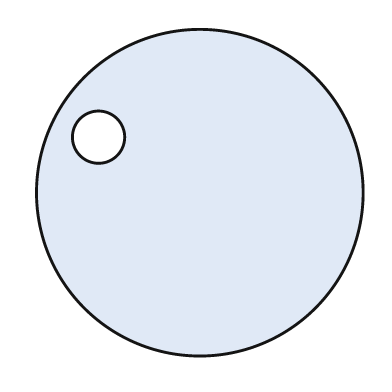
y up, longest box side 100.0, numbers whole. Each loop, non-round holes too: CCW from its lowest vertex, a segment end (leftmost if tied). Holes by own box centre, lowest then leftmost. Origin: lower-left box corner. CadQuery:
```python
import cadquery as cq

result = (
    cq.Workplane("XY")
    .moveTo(50.0, 50.0)
    .circle(50.0)
    .moveTo(19.0, 67.0)
    .circle(8.0)
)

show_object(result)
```